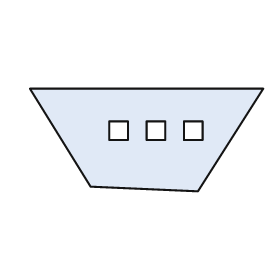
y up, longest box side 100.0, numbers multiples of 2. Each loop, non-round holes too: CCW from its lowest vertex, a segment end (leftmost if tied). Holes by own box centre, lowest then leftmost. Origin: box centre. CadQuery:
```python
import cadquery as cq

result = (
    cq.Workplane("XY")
    .moveTo(22.0, -22.0)
    .lineTo(50.0, 22.0)
    .lineTo(-50.0, 22.0)
    .lineTo(-24.0, -20.0)
    .close()
    .moveTo(-16.0, 0.0)
    .lineTo(-8.0, 0.0)
    .lineTo(-8.0, 8.0)
    .lineTo(-16.0, 8.0)
    .close()
    .moveTo(0.0, 0.0)
    .lineTo(8.0, 0.0)
    .lineTo(8.0, 8.0)
    .lineTo(0.0, 8.0)
    .close()
    .moveTo(16.0, 0.0)
    .lineTo(24.0, 0.0)
    .lineTo(24.0, 8.0)
    .lineTo(16.0, 8.0)
    .close()
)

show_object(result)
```